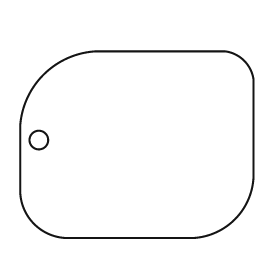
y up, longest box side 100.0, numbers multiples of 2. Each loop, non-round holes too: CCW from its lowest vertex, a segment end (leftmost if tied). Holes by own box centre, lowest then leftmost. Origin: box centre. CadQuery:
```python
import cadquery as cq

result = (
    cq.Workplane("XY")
    .moveTo(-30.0, -40.0)
    .lineTo(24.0, -40.0)
    .threePointArc((42.0, -32.0), (50.0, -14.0))
    .lineTo(50.0, 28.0)
    .threePointArc((46.0, 36.0), (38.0, 40.0))
    .lineTo(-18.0, 40.0)
    .threePointArc((-40.0, 30.0), (-50.0, 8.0))
    .lineTo(-50.0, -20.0)
    .threePointArc((-44.0, -34.0), (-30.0, -40.0))
    .close()
    .moveTo(-42.0, 2.0)
    .circle(4.0)
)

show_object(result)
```